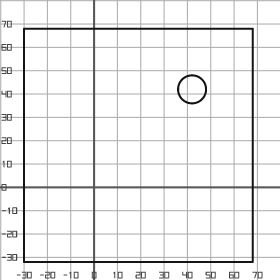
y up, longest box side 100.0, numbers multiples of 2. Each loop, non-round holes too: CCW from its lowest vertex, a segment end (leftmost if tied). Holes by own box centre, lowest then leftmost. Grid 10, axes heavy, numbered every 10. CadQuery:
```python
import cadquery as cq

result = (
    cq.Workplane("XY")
    .moveTo(-30.0, -32.0)
    .lineTo(68.0, -32.0)
    .lineTo(68.0, 68.0)
    .lineTo(-30.0, 68.0)
    .close()
    .moveTo(42.0, 42.0)
    .circle(6.0)
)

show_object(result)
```